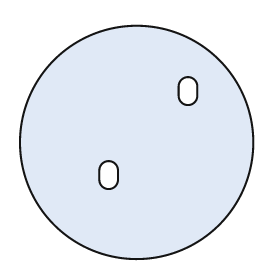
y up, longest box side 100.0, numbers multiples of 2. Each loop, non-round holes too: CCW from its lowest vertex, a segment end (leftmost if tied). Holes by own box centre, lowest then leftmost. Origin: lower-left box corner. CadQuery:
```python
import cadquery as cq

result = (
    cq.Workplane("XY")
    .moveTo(50.0, 50.0)
    .circle(50.0)
    .moveTo(34.0, 34.0)
    .threePointArc((38.0, 30.0), (42.0, 34.0))
    .lineTo(42.0, 38.0)
    .threePointArc((38.0, 42.0), (34.0, 38.0))
    .close()
    .moveTo(68.0, 70.0)
    .threePointArc((72.0, 66.0), (76.0, 70.0))
    .lineTo(76.0, 74.0)
    .threePointArc((72.0, 78.0), (68.0, 74.0))
    .close()
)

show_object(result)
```